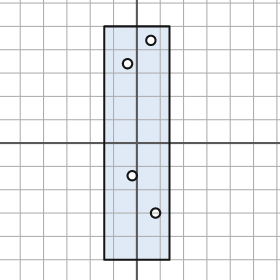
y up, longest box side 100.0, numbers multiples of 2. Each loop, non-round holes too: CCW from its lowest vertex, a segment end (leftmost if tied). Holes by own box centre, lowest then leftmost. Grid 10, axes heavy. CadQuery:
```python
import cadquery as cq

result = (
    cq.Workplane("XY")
    .moveTo(-14.0, -50.0)
    .lineTo(14.0, -50.0)
    .lineTo(14.0, 50.0)
    .lineTo(-14.0, 50.0)
    .close()
    .moveTo(8.0, -30.0)
    .circle(2.0)
    .moveTo(-2.0, -14.0)
    .circle(2.0)
    .moveTo(-4.0, 34.0)
    .circle(2.0)
    .moveTo(6.0, 44.0)
    .circle(2.0)
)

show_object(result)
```